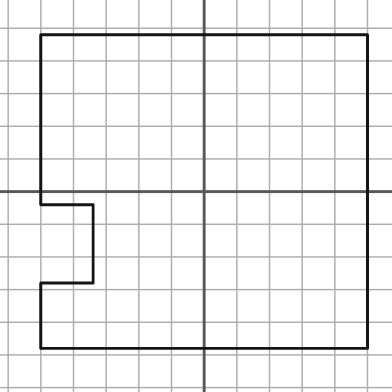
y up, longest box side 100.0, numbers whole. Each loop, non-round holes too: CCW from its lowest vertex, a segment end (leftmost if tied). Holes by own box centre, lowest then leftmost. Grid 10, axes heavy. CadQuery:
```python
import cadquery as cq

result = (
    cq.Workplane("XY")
    .moveTo(-50.0, -48.0)
    .lineTo(50.0, -48.0)
    .lineTo(50.0, 48.0)
    .lineTo(-50.0, 48.0)
    .lineTo(-50.0, -4.0)
    .lineTo(-34.0, -4.0)
    .lineTo(-34.0, -28.0)
    .lineTo(-50.0, -28.0)
    .close()
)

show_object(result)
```